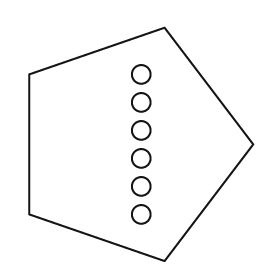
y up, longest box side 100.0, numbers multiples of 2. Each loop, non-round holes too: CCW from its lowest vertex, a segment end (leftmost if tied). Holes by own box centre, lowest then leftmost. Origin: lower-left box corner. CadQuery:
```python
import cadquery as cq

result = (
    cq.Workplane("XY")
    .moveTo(58.0, 0.0)
    .lineTo(96.0, 50.0)
    .lineTo(58.0, 100.0)
    .lineTo(0.0, 80.0)
    .lineTo(0.0, 20.0)
    .close()
    .moveTo(48.0, 20.0)
    .circle(4.0)
    .moveTo(48.0, 32.0)
    .circle(4.0)
    .moveTo(48.0, 44.0)
    .circle(4.0)
    .moveTo(48.0, 56.0)
    .circle(4.0)
    .moveTo(48.0, 68.0)
    .circle(4.0)
    .moveTo(48.0, 80.0)
    .circle(4.0)
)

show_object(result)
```